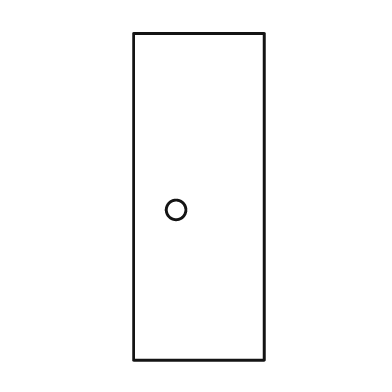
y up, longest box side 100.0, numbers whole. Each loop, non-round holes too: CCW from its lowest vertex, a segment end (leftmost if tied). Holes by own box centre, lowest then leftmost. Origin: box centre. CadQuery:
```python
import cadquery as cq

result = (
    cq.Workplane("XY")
    .moveTo(-20.0, -50.0)
    .lineTo(20.0, -50.0)
    .lineTo(20.0, 50.0)
    .lineTo(-20.0, 50.0)
    .close()
    .moveTo(-7.0, -4.0)
    .circle(3.0)
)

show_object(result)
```